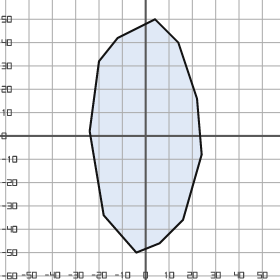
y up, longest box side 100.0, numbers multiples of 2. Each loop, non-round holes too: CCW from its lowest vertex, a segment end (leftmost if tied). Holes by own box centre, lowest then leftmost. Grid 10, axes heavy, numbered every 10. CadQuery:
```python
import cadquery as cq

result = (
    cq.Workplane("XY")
    .moveTo(-4.0, -50.0)
    .lineTo(6.0, -46.0)
    .lineTo(16.0, -36.0)
    .lineTo(24.0, -8.0)
    .lineTo(22.0, 16.0)
    .lineTo(14.0, 40.0)
    .lineTo(4.0, 50.0)
    .lineTo(-12.0, 42.0)
    .lineTo(-20.0, 32.0)
    .lineTo(-24.0, 2.0)
    .lineTo(-18.0, -34.0)
    .close()
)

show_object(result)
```